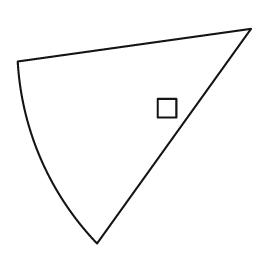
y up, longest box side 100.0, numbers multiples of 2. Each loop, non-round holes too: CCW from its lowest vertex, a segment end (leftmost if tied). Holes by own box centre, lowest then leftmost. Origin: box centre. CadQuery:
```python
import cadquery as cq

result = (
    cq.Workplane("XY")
    .moveTo(-16.0, -46.0)
    .lineTo(50.0, 46.0)
    .lineTo(-50.0, 32.0)
    .threePointArc((-40.0, -10.0), (-16.0, -46.0))
    .close()
    .moveTo(10.0, 8.0)
    .lineTo(18.0, 8.0)
    .lineTo(18.0, 16.0)
    .lineTo(10.0, 16.0)
    .close()
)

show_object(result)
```